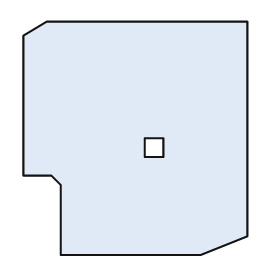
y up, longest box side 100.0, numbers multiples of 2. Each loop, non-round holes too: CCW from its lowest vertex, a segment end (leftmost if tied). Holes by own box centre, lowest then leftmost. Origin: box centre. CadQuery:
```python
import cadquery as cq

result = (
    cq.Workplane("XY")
    .moveTo(-32.0, -50.0)
    .lineTo(28.0, -50.0)
    .lineTo(48.0, -42.0)
    .lineTo(48.0, 50.0)
    .lineTo(-38.0, 50.0)
    .lineTo(-48.0, 44.0)
    .lineTo(-48.0, -16.0)
    .lineTo(-36.0, -16.0)
    .lineTo(-32.0, -20.0)
    .close()
    .moveTo(4.0, -8.0)
    .lineTo(12.0, -8.0)
    .lineTo(12.0, 0.0)
    .lineTo(4.0, 0.0)
    .close()
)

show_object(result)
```